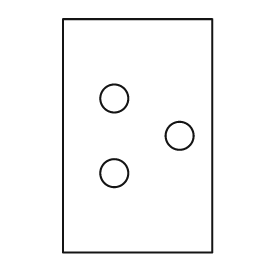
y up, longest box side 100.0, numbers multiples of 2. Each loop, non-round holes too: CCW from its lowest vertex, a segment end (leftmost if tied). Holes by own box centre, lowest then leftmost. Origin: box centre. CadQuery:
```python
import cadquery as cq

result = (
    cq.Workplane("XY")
    .moveTo(-32.0, -50.0)
    .lineTo(32.0, -50.0)
    .lineTo(32.0, 50.0)
    .lineTo(-32.0, 50.0)
    .close()
    .moveTo(-10.0, -16.0)
    .circle(6.0)
    .moveTo(18.0, 0.0)
    .circle(6.0)
    .moveTo(-10.0, 16.0)
    .circle(6.0)
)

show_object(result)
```